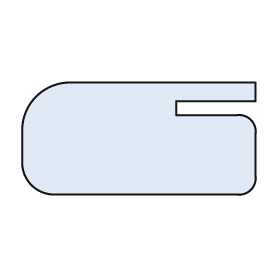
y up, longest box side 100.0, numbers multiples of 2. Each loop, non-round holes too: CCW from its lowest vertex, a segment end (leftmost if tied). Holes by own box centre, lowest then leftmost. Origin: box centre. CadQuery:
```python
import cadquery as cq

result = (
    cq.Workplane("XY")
    .moveTo(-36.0, -24.0)
    .lineTo(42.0, -24.0)
    .threePointArc((48.0, -22.0), (50.0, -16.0))
    .lineTo(50.0, 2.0)
    .threePointArc((48.0, 8.0), (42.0, 10.0))
    .lineTo(16.0, 10.0)
    .lineTo(16.0, 16.0)
    .lineTo(50.0, 16.0)
    .lineTo(50.0, 24.0)
    .lineTo(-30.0, 24.0)
    .threePointArc((-44.0, 18.0), (-50.0, 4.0))
    .lineTo(-50.0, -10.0)
    .threePointArc((-46.0, -20.0), (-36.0, -24.0))
    .close()
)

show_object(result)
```